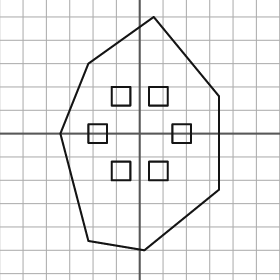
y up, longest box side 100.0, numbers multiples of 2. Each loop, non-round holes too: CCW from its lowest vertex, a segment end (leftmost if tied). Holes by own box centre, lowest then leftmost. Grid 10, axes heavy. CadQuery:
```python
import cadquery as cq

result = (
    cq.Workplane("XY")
    .moveTo(2.0, -50.0)
    .lineTo(34.0, -24.0)
    .lineTo(34.0, 16.0)
    .lineTo(6.0, 50.0)
    .lineTo(-22.0, 30.0)
    .lineTo(-34.0, 0.0)
    .lineTo(-22.0, -46.0)
    .close()
    .moveTo(-12.0, -20.0)
    .lineTo(-4.0, -20.0)
    .lineTo(-4.0, -12.0)
    .lineTo(-12.0, -12.0)
    .close()
    .moveTo(4.0, -20.0)
    .lineTo(12.0, -20.0)
    .lineTo(12.0, -12.0)
    .lineTo(4.0, -12.0)
    .close()
    .moveTo(-22.0, -4.0)
    .lineTo(-14.0, -4.0)
    .lineTo(-14.0, 4.0)
    .lineTo(-22.0, 4.0)
    .close()
    .moveTo(14.0, -4.0)
    .lineTo(22.0, -4.0)
    .lineTo(22.0, 4.0)
    .lineTo(14.0, 4.0)
    .close()
    .moveTo(-12.0, 12.0)
    .lineTo(-4.0, 12.0)
    .lineTo(-4.0, 20.0)
    .lineTo(-12.0, 20.0)
    .close()
    .moveTo(4.0, 12.0)
    .lineTo(12.0, 12.0)
    .lineTo(12.0, 20.0)
    .lineTo(4.0, 20.0)
    .close()
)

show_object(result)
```